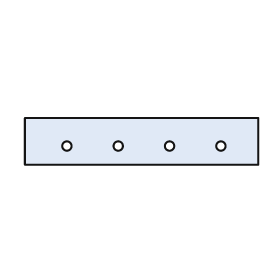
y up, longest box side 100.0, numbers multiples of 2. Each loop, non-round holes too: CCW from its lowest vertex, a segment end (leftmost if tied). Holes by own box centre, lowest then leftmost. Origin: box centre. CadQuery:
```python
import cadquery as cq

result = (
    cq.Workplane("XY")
    .moveTo(-50.0, -10.0)
    .lineTo(50.0, -10.0)
    .lineTo(50.0, 10.0)
    .lineTo(-50.0, 10.0)
    .close()
    .moveTo(-32.0, -2.0)
    .circle(2.0)
    .moveTo(-10.0, -2.0)
    .circle(2.0)
    .moveTo(12.0, -2.0)
    .circle(2.0)
    .moveTo(34.0, -2.0)
    .circle(2.0)
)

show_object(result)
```